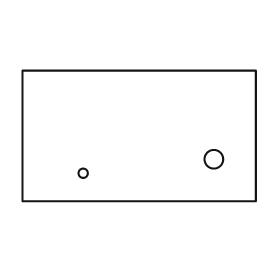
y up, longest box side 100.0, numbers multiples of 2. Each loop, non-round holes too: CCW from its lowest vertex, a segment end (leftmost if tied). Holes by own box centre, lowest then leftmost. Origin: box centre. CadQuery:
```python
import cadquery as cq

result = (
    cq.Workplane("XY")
    .moveTo(-50.0, -28.0)
    .lineTo(50.0, -28.0)
    .lineTo(50.0, 28.0)
    .lineTo(-50.0, 28.0)
    .close()
    .moveTo(-24.0, -16.0)
    .circle(2.0)
    .moveTo(32.0, -10.0)
    .circle(4.0)
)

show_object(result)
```